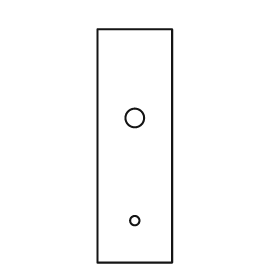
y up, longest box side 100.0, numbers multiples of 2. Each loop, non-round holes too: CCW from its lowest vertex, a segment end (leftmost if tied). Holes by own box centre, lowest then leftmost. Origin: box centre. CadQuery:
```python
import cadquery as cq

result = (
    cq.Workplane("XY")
    .moveTo(-16.0, -50.0)
    .lineTo(16.0, -50.0)
    .lineTo(16.0, 50.0)
    .lineTo(-16.0, 50.0)
    .close()
    .moveTo(0.0, -32.0)
    .circle(2.0)
    .moveTo(0.0, 12.0)
    .circle(4.0)
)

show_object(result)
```